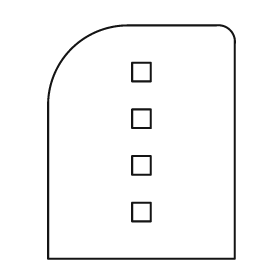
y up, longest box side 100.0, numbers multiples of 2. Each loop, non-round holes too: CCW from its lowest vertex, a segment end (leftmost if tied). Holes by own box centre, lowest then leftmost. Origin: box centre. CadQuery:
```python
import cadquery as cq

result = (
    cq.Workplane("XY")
    .moveTo(-40.0, -50.0)
    .lineTo(40.0, -50.0)
    .lineTo(40.0, 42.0)
    .threePointArc((38.0, 48.0), (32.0, 50.0))
    .lineTo(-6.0, 50.0)
    .threePointArc((-30.0, 40.0), (-40.0, 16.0))
    .close()
    .moveTo(-4.0, -34.0)
    .lineTo(4.0, -34.0)
    .lineTo(4.0, -26.0)
    .lineTo(-4.0, -26.0)
    .close()
    .moveTo(-4.0, -14.0)
    .lineTo(4.0, -14.0)
    .lineTo(4.0, -6.0)
    .lineTo(-4.0, -6.0)
    .close()
    .moveTo(-4.0, 6.0)
    .lineTo(4.0, 6.0)
    .lineTo(4.0, 14.0)
    .lineTo(-4.0, 14.0)
    .close()
    .moveTo(-4.0, 26.0)
    .lineTo(4.0, 26.0)
    .lineTo(4.0, 34.0)
    .lineTo(-4.0, 34.0)
    .close()
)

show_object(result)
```